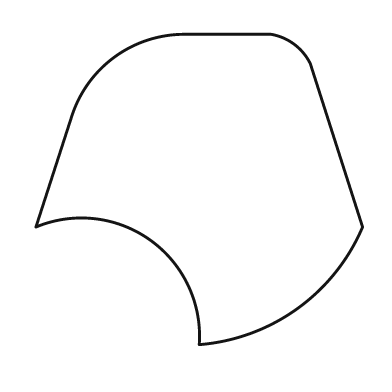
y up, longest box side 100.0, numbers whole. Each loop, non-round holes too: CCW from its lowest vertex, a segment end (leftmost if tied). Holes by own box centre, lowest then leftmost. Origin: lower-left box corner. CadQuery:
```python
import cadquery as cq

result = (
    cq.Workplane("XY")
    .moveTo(50.0, 0.0)
    .threePointArc((80.0, 11.0), (100.0, 36.0))
    .lineTo(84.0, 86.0)
    .threePointArc((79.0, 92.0), (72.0, 95.0))
    .lineTo(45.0, 95.0)
    .threePointArc((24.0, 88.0), (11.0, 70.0))
    .lineTo(0.0, 36.0)
    .threePointArc((35.0, 32.0), (50.0, 0.0))
    .close()
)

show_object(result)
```